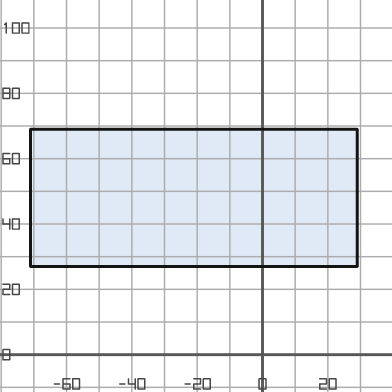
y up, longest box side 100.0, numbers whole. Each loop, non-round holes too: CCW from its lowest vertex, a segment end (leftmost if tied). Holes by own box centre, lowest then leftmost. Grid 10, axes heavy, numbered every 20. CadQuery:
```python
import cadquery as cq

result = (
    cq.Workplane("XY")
    .moveTo(-71.0, 27.0)
    .lineTo(29.0, 27.0)
    .lineTo(29.0, 69.0)
    .lineTo(-71.0, 69.0)
    .close()
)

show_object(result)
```